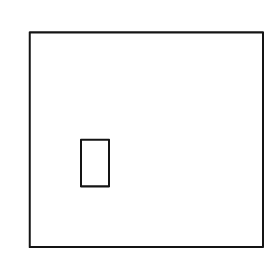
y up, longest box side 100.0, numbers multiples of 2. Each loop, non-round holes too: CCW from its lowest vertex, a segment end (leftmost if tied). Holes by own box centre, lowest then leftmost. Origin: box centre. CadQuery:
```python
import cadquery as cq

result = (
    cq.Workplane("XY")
    .moveTo(-50.0, -46.0)
    .lineTo(50.0, -46.0)
    .lineTo(50.0, 46.0)
    .lineTo(-50.0, 46.0)
    .close()
    .moveTo(-28.0, -20.0)
    .lineTo(-16.0, -20.0)
    .lineTo(-16.0, 0.0)
    .lineTo(-28.0, 0.0)
    .close()
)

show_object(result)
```